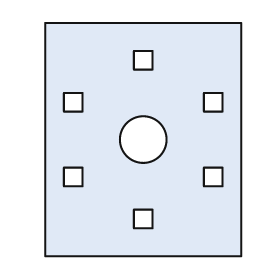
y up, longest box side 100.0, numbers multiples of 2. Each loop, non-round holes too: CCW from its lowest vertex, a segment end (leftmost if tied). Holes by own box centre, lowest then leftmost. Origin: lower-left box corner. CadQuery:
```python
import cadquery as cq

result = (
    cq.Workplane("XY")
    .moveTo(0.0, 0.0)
    .lineTo(84.0, 0.0)
    .lineTo(84.0, 100.0)
    .lineTo(0.0, 100.0)
    .close()
    .moveTo(38.0, 12.0)
    .lineTo(46.0, 12.0)
    .lineTo(46.0, 20.0)
    .lineTo(38.0, 20.0)
    .close()
    .moveTo(8.0, 30.0)
    .lineTo(16.0, 30.0)
    .lineTo(16.0, 38.0)
    .lineTo(8.0, 38.0)
    .close()
    .moveTo(68.0, 30.0)
    .lineTo(76.0, 30.0)
    .lineTo(76.0, 38.0)
    .lineTo(68.0, 38.0)
    .close()
    .moveTo(42.0, 50.0)
    .circle(10.0)
    .moveTo(8.0, 62.0)
    .lineTo(16.0, 62.0)
    .lineTo(16.0, 70.0)
    .lineTo(8.0, 70.0)
    .close()
    .moveTo(68.0, 62.0)
    .lineTo(76.0, 62.0)
    .lineTo(76.0, 70.0)
    .lineTo(68.0, 70.0)
    .close()
    .moveTo(38.0, 80.0)
    .lineTo(46.0, 80.0)
    .lineTo(46.0, 88.0)
    .lineTo(38.0, 88.0)
    .close()
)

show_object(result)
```